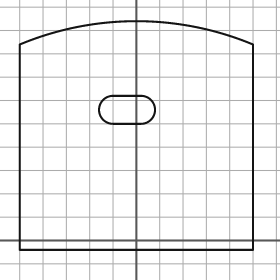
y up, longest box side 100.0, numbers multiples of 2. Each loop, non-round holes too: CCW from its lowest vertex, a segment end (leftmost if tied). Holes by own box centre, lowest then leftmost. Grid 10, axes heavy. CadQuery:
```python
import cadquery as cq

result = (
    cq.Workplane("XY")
    .moveTo(-50.0, -4.0)
    .lineTo(50.0, -4.0)
    .lineTo(50.0, 84.0)
    .threePointArc((0.0, 94.0), (-50.0, 84.0))
    .close()
    .moveTo(-10.0, 50.0)
    .lineTo(2.0, 50.0)
    .threePointArc((8.0, 56.0), (2.0, 62.0))
    .lineTo(-10.0, 62.0)
    .threePointArc((-16.0, 56.0), (-10.0, 50.0))
    .close()
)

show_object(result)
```